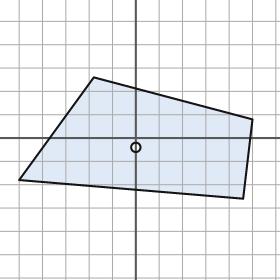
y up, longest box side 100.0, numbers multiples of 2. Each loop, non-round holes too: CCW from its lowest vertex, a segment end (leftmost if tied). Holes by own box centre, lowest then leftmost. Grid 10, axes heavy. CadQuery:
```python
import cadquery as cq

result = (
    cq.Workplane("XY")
    .moveTo(46.0, -26.0)
    .lineTo(50.0, 8.0)
    .lineTo(-18.0, 26.0)
    .lineTo(-50.0, -18.0)
    .close()
    .moveTo(0.0, -4.0)
    .circle(2.0)
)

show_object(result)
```